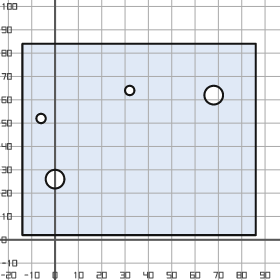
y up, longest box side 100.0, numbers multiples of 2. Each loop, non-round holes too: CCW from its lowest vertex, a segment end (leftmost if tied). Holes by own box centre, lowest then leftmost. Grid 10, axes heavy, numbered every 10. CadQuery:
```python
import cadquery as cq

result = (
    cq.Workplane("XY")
    .moveTo(-14.0, 2.0)
    .lineTo(86.0, 2.0)
    .lineTo(86.0, 84.0)
    .lineTo(-14.0, 84.0)
    .close()
    .moveTo(0.0, 26.0)
    .circle(4.0)
    .moveTo(-6.0, 52.0)
    .circle(2.0)
    .moveTo(68.0, 62.0)
    .circle(4.0)
    .moveTo(32.0, 64.0)
    .circle(2.0)
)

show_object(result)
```